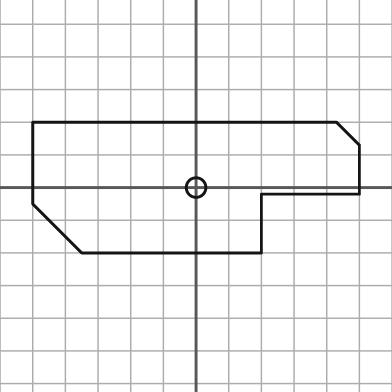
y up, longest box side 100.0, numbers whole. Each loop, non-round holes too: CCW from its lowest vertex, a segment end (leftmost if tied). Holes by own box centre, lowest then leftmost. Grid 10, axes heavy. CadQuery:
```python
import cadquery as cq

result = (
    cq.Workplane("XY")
    .moveTo(-35.0, -20.0)
    .lineTo(20.0, -20.0)
    .lineTo(20.0, -2.0)
    .lineTo(50.0, -2.0)
    .lineTo(50.0, 13.0)
    .lineTo(43.0, 20.0)
    .lineTo(-50.0, 20.0)
    .lineTo(-50.0, -5.0)
    .close()
    .moveTo(0.0, 0.0)
    .circle(3.0)
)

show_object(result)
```